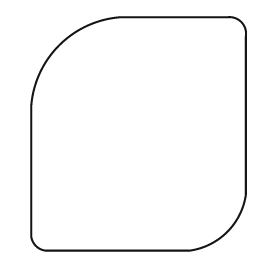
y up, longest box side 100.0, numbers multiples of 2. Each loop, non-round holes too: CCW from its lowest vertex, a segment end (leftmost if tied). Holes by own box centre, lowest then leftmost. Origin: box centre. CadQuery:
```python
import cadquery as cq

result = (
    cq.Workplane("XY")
    .moveTo(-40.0, -50.0)
    .lineTo(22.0, -50.0)
    .threePointArc((38.0, -42.0), (46.0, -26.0))
    .lineTo(46.0, 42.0)
    .threePointArc((44.0, 48.0), (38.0, 50.0))
    .lineTo(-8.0, 50.0)
    .threePointArc((-34.0, 38.0), (-46.0, 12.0))
    .lineTo(-46.0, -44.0)
    .threePointArc((-44.0, -48.0), (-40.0, -50.0))
    .close()
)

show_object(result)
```